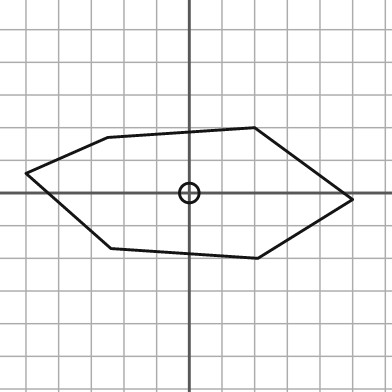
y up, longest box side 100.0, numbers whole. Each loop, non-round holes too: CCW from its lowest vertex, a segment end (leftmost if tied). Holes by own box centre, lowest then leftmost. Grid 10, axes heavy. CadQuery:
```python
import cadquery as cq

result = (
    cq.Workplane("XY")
    .moveTo(21.0, -20.0)
    .lineTo(50.0, -2.0)
    .lineTo(20.0, 20.0)
    .lineTo(-25.0, 17.0)
    .lineTo(-50.0, 6.0)
    .lineTo(-24.0, -17.0)
    .close()
    .moveTo(0.0, 0.0)
    .circle(3.0)
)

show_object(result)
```